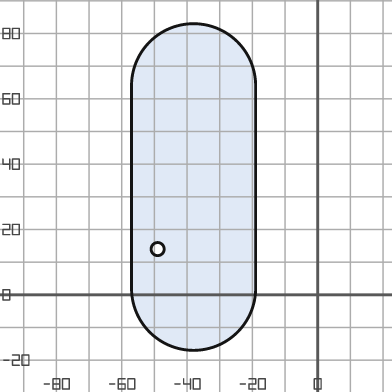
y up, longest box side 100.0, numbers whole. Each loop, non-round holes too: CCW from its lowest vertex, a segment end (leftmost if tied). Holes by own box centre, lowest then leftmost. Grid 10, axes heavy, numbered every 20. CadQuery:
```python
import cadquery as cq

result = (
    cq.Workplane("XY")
    .moveTo(-57.0, 2.0)
    .threePointArc((-38.0, -17.0), (-19.0, 2.0))
    .lineTo(-19.0, 64.0)
    .threePointArc((-38.0, 83.0), (-57.0, 64.0))
    .close()
    .moveTo(-49.0, 14.0)
    .circle(2.0)
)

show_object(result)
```